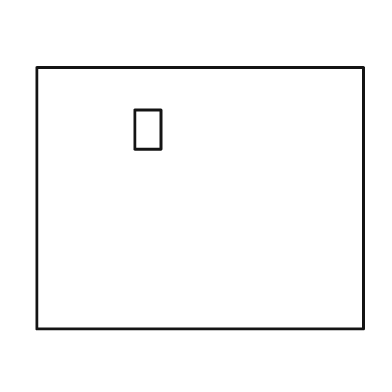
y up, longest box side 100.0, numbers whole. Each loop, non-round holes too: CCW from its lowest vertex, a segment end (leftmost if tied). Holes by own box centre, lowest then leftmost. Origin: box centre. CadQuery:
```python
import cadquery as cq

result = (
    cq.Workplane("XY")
    .moveTo(-50.0, -40.0)
    .lineTo(50.0, -40.0)
    .lineTo(50.0, 40.0)
    .lineTo(-50.0, 40.0)
    .close()
    .moveTo(-20.0, 15.0)
    .lineTo(-12.0, 15.0)
    .lineTo(-12.0, 27.0)
    .lineTo(-20.0, 27.0)
    .close()
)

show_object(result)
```